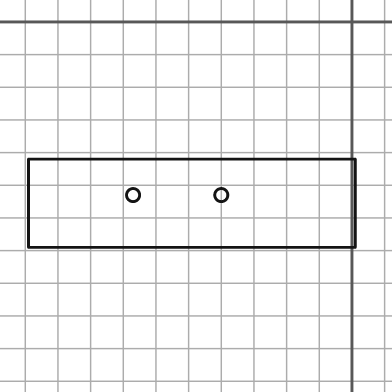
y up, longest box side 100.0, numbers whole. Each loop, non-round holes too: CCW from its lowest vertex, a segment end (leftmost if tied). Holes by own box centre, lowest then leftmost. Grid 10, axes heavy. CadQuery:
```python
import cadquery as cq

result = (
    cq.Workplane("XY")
    .moveTo(-99.0, -69.0)
    .lineTo(1.0, -69.0)
    .lineTo(1.0, -42.0)
    .lineTo(-99.0, -42.0)
    .close()
    .moveTo(-67.0, -53.0)
    .circle(2.0)
    .moveTo(-40.0, -53.0)
    .circle(2.0)
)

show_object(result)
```